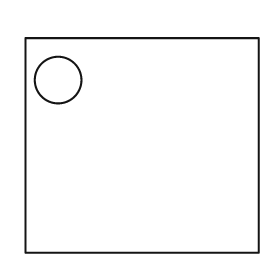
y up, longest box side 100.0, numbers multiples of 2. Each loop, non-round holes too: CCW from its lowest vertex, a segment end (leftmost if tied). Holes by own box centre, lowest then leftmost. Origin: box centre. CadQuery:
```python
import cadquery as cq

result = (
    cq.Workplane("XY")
    .moveTo(-50.0, -46.0)
    .lineTo(50.0, -46.0)
    .lineTo(50.0, 46.0)
    .lineTo(-50.0, 46.0)
    .close()
    .moveTo(-36.0, 28.0)
    .circle(10.0)
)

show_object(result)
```